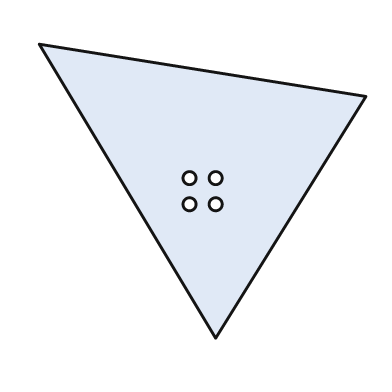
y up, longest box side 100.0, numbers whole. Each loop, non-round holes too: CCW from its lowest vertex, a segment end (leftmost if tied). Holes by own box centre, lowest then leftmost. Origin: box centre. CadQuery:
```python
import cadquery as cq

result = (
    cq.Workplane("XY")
    .moveTo(4.0, -45.0)
    .lineTo(50.0, 29.0)
    .lineTo(-50.0, 45.0)
    .close()
    .moveTo(-4.0, -4.0)
    .circle(2.0)
    .moveTo(4.0, -4.0)
    .circle(2.0)
    .moveTo(-4.0, 4.0)
    .circle(2.0)
    .moveTo(4.0, 4.0)
    .circle(2.0)
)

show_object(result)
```